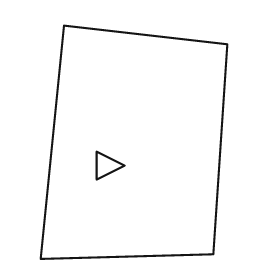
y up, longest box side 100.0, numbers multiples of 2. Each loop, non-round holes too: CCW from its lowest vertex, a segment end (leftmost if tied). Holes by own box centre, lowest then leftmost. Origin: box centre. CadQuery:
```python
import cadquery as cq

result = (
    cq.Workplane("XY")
    .moveTo(-40.0, -50.0)
    .lineTo(34.0, -48.0)
    .lineTo(40.0, 42.0)
    .lineTo(-30.0, 50.0)
    .close()
    .moveTo(-16.0, -16.0)
    .lineTo(-4.0, -10.0)
    .lineTo(-16.0, -4.0)
    .close()
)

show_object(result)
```